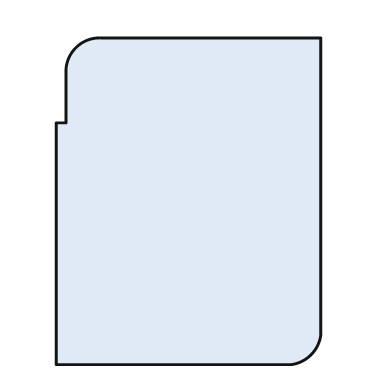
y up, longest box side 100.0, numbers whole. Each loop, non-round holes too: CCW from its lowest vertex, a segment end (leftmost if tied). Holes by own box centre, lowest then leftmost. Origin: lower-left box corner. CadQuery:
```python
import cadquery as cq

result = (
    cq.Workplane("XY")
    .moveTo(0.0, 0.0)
    .lineTo(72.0, 0.0)
    .threePointArc((78.0, 3.0), (81.0, 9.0))
    .lineTo(81.0, 100.0)
    .lineTo(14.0, 100.0)
    .threePointArc((6.0, 97.0), (3.0, 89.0))
    .lineTo(3.0, 74.0)
    .lineTo(0.0, 74.0)
    .close()
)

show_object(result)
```